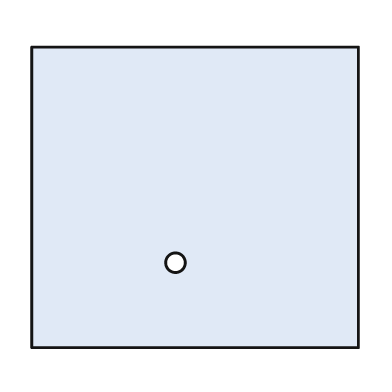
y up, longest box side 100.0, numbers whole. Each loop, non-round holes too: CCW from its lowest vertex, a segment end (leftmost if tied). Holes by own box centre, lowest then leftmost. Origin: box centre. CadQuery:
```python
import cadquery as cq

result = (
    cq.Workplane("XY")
    .moveTo(-50.0, -46.0)
    .lineTo(50.0, -46.0)
    .lineTo(50.0, 46.0)
    .lineTo(-50.0, 46.0)
    .close()
    .moveTo(-6.0, -20.0)
    .circle(3.0)
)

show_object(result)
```